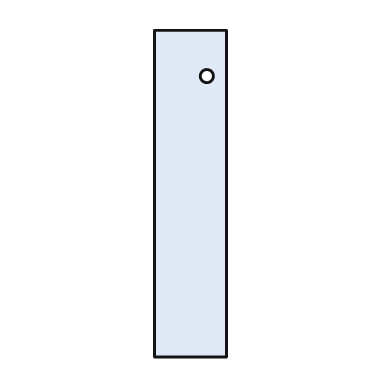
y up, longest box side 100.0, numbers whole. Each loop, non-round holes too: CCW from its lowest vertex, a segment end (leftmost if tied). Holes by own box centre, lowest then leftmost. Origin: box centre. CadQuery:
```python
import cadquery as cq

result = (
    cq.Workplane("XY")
    .moveTo(-11.0, -50.0)
    .lineTo(11.0, -50.0)
    .lineTo(11.0, 50.0)
    .lineTo(-11.0, 50.0)
    .close()
    .moveTo(5.0, 36.0)
    .circle(2.0)
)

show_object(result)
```